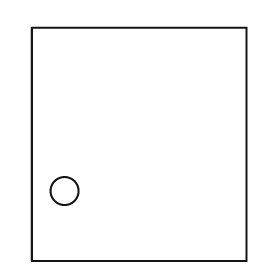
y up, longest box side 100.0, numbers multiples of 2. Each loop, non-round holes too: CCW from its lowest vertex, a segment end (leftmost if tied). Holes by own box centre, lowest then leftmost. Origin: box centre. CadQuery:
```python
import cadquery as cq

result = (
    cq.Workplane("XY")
    .moveTo(-46.0, -50.0)
    .lineTo(46.0, -50.0)
    .lineTo(46.0, 50.0)
    .lineTo(-46.0, 50.0)
    .close()
    .moveTo(-32.0, -20.0)
    .circle(6.0)
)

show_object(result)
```